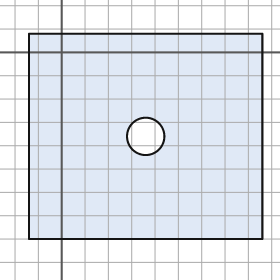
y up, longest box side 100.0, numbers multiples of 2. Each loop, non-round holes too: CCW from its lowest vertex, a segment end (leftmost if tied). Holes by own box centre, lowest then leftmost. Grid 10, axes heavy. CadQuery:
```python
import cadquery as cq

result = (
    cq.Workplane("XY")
    .moveTo(-14.0, -80.0)
    .lineTo(86.0, -80.0)
    .lineTo(86.0, 8.0)
    .lineTo(-14.0, 8.0)
    .close()
    .moveTo(36.0, -36.0)
    .circle(8.0)
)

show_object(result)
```